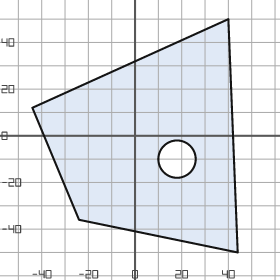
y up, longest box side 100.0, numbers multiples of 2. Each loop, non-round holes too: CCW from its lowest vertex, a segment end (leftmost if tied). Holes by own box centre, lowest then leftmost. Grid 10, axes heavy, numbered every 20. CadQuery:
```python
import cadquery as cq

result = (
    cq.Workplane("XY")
    .moveTo(44.0, -50.0)
    .lineTo(40.0, 50.0)
    .lineTo(-44.0, 12.0)
    .lineTo(-24.0, -36.0)
    .close()
    .moveTo(18.0, -10.0)
    .circle(8.0)
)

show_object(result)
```